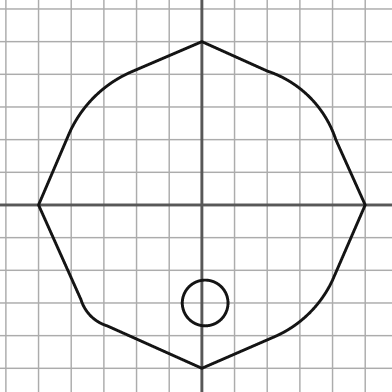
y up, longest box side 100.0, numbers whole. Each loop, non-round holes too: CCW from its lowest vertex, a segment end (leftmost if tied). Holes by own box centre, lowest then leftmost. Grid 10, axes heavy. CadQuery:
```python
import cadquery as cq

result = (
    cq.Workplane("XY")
    .moveTo(0.0, -50.0)
    .lineTo(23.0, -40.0)
    .threePointArc((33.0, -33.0), (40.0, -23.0))
    .lineTo(50.0, 0.0)
    .lineTo(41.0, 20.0)
    .threePointArc((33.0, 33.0), (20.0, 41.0))
    .lineTo(0.0, 50.0)
    .lineTo(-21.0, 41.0)
    .threePointArc((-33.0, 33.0), (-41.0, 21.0))
    .lineTo(-50.0, 0.0)
    .lineTo(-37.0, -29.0)
    .threePointArc((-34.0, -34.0), (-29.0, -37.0))
    .close()
    .moveTo(1.0, -30.0)
    .circle(7.0)
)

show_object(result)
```